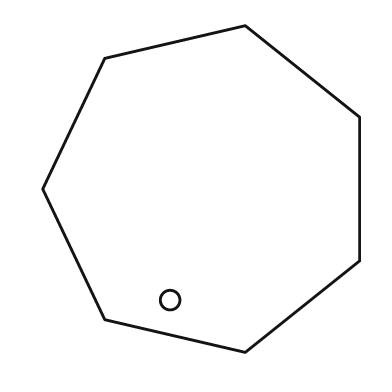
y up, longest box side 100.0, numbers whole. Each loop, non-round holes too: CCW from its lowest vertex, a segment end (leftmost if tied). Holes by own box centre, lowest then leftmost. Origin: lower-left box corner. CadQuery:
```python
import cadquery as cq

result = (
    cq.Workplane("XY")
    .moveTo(62.0, 0.0)
    .lineTo(97.0, 28.0)
    .lineTo(97.0, 72.0)
    .lineTo(62.0, 100.0)
    .lineTo(19.0, 90.0)
    .lineTo(0.0, 50.0)
    .lineTo(19.0, 10.0)
    .close()
    .moveTo(39.0, 16.0)
    .circle(3.0)
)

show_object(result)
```